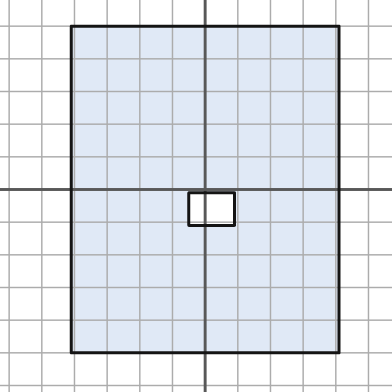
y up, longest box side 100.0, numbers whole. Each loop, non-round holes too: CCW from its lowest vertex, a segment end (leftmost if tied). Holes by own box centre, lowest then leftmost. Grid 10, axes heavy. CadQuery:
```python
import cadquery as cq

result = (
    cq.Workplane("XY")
    .moveTo(-41.0, -50.0)
    .lineTo(41.0, -50.0)
    .lineTo(41.0, 50.0)
    .lineTo(-41.0, 50.0)
    .close()
    .moveTo(-5.0, -11.0)
    .lineTo(9.0, -11.0)
    .lineTo(9.0, -1.0)
    .lineTo(-5.0, -1.0)
    .close()
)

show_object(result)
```